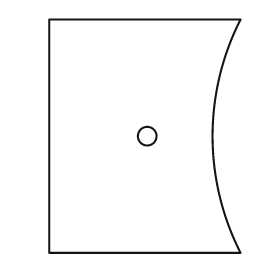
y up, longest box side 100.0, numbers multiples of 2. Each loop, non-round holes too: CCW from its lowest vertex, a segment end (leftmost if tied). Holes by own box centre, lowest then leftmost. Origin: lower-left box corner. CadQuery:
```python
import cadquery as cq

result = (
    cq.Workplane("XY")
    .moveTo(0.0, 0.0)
    .lineTo(82.0, 0.0)
    .threePointArc((70.0, 50.0), (82.0, 100.0))
    .lineTo(0.0, 100.0)
    .close()
    .moveTo(42.0, 50.0)
    .circle(4.0)
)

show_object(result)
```